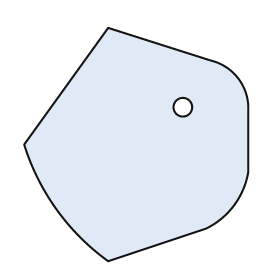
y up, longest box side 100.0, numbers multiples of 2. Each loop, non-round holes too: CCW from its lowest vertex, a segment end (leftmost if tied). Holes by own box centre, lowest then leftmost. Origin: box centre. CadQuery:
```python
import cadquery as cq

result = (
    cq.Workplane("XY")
    .moveTo(-12.0, -50.0)
    .lineTo(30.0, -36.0)
    .threePointArc((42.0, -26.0), (48.0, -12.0))
    .lineTo(48.0, 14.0)
    .threePointArc((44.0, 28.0), (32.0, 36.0))
    .lineTo(-12.0, 50.0)
    .lineTo(-48.0, 0.0)
    .threePointArc((-34.0, -28.0), (-12.0, -50.0))
    .close()
    .moveTo(20.0, 16.0)
    .circle(4.0)
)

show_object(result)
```